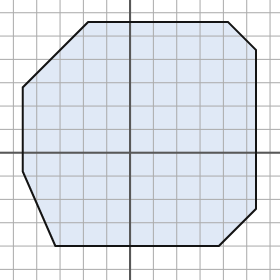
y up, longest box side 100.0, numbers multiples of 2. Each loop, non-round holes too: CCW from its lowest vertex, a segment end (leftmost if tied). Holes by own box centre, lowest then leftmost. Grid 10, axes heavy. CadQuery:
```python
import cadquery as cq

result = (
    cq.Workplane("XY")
    .moveTo(-32.0, -40.0)
    .lineTo(38.0, -40.0)
    .lineTo(54.0, -24.0)
    .lineTo(54.0, 44.0)
    .lineTo(42.0, 56.0)
    .lineTo(-18.0, 56.0)
    .lineTo(-46.0, 28.0)
    .lineTo(-46.0, -8.0)
    .close()
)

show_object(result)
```